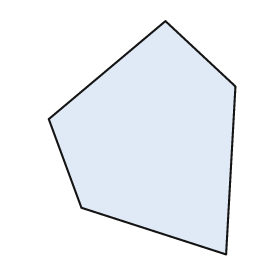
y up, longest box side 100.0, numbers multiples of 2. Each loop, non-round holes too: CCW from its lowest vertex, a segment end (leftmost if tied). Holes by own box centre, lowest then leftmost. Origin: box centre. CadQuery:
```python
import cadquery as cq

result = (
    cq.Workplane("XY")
    .moveTo(36.0, -50.0)
    .lineTo(40.0, 22.0)
    .lineTo(10.0, 50.0)
    .lineTo(-40.0, 8.0)
    .lineTo(-26.0, -30.0)
    .close()
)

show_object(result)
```